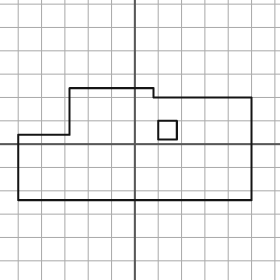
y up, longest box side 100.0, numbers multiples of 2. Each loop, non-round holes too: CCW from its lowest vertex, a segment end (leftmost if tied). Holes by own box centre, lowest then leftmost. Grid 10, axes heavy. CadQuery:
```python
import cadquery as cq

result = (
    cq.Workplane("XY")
    .moveTo(-50.0, -24.0)
    .lineTo(50.0, -24.0)
    .lineTo(50.0, 20.0)
    .lineTo(8.0, 20.0)
    .lineTo(8.0, 24.0)
    .lineTo(-28.0, 24.0)
    .lineTo(-28.0, 4.0)
    .lineTo(-50.0, 4.0)
    .close()
    .moveTo(10.0, 2.0)
    .lineTo(18.0, 2.0)
    .lineTo(18.0, 10.0)
    .lineTo(10.0, 10.0)
    .close()
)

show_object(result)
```